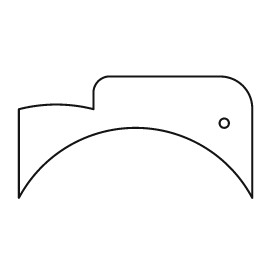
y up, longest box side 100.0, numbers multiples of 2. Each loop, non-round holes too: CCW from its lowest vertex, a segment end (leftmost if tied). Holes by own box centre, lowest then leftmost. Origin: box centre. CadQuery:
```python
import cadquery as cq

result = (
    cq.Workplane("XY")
    .moveTo(-50.0, -26.0)
    .threePointArc((0.0, 4.0), (50.0, -26.0))
    .lineTo(50.0, 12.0)
    .threePointArc((46.0, 22.0), (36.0, 26.0))
    .lineTo(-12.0, 26.0)
    .threePointArc((-16.0, 24.0), (-18.0, 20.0))
    .lineTo(-18.0, 12.0)
    .threePointArc((-34.0, 14.0), (-50.0, 12.0))
    .close()
    .moveTo(38.0, 6.0)
    .circle(2.0)
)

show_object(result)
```